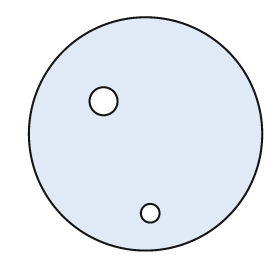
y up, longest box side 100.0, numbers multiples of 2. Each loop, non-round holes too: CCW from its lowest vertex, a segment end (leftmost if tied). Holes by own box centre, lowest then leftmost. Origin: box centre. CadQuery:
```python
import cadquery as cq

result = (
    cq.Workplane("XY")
    .moveTo(0.0, 0.0)
    .circle(50.0)
    .moveTo(2.0, -34.0)
    .circle(4.0)
    .moveTo(-18.0, 14.0)
    .circle(6.0)
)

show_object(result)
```